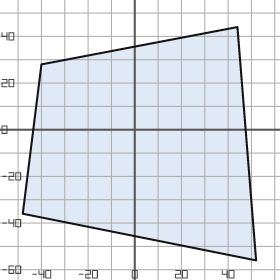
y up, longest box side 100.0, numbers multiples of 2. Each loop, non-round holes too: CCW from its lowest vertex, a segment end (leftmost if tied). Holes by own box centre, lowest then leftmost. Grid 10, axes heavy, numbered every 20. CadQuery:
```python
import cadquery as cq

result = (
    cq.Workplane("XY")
    .moveTo(52.0, -56.0)
    .lineTo(44.0, 44.0)
    .lineTo(-40.0, 28.0)
    .lineTo(-48.0, -36.0)
    .close()
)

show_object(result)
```